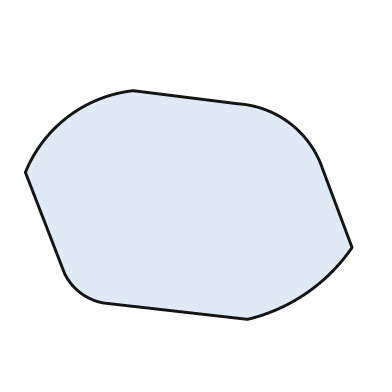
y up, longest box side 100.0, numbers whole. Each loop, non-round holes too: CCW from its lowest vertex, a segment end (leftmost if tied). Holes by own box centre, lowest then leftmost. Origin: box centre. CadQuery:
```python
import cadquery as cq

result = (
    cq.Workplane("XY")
    .moveTo(18.0, -35.0)
    .threePointArc((36.0, -27.0), (50.0, -13.0))
    .lineTo(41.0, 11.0)
    .threePointArc((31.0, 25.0), (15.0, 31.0))
    .lineTo(-17.0, 35.0)
    .threePointArc((-37.0, 27.0), (-50.0, 10.0))
    .lineTo(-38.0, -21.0)
    .threePointArc((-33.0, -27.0), (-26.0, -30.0))
    .close()
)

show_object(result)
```